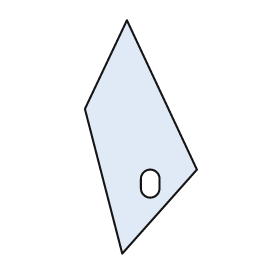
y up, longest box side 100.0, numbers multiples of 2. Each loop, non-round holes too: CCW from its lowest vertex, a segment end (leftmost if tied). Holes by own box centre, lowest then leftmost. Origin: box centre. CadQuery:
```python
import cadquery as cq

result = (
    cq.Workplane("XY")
    .moveTo(-8.0, -50.0)
    .lineTo(24.0, -14.0)
    .lineTo(-6.0, 50.0)
    .lineTo(-24.0, 12.0)
    .close()
    .moveTo(0.0, -22.0)
    .threePointArc((4.0, -26.0), (8.0, -22.0))
    .lineTo(8.0, -18.0)
    .threePointArc((4.0, -14.0), (0.0, -18.0))
    .close()
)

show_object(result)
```